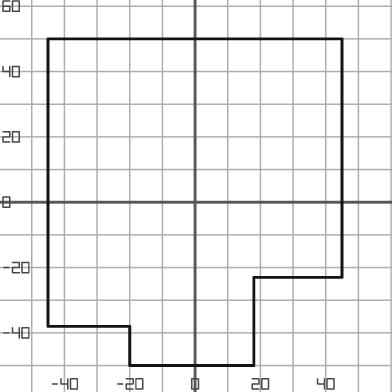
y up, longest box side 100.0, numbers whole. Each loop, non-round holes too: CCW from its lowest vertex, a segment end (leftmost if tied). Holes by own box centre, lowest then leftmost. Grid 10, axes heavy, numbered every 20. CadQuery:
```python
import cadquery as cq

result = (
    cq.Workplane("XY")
    .moveTo(-20.0, -50.0)
    .lineTo(18.0, -50.0)
    .lineTo(18.0, -23.0)
    .lineTo(45.0, -23.0)
    .lineTo(45.0, 50.0)
    .lineTo(-45.0, 50.0)
    .lineTo(-45.0, -38.0)
    .lineTo(-20.0, -38.0)
    .close()
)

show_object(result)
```